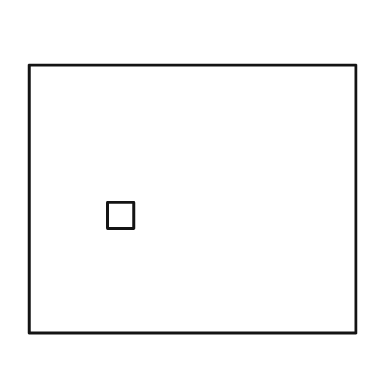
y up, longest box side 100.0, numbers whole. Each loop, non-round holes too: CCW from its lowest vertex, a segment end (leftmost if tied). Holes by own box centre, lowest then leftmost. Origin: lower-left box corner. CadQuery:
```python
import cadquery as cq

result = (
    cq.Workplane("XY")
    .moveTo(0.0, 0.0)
    .lineTo(100.0, 0.0)
    .lineTo(100.0, 82.0)
    .lineTo(0.0, 82.0)
    .close()
    .moveTo(24.0, 32.0)
    .lineTo(32.0, 32.0)
    .lineTo(32.0, 40.0)
    .lineTo(24.0, 40.0)
    .close()
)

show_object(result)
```